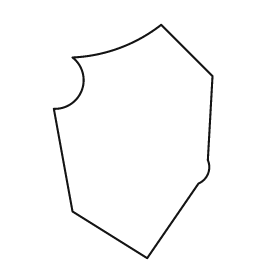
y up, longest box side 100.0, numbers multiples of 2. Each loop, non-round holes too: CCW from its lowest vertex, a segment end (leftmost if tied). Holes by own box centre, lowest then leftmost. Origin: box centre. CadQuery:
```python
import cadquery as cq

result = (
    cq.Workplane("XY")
    .moveTo(6.0, -50.0)
    .lineTo(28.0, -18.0)
    .threePointArc((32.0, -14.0), (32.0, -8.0))
    .lineTo(34.0, 28.0)
    .lineTo(12.0, 50.0)
    .threePointArc((-6.0, 40.0), (-26.0, 36.0))
    .threePointArc((-22.0, 22.0), (-34.0, 14.0))
    .lineTo(-26.0, -30.0)
    .close()
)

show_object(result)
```